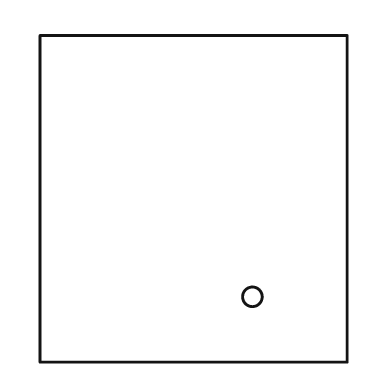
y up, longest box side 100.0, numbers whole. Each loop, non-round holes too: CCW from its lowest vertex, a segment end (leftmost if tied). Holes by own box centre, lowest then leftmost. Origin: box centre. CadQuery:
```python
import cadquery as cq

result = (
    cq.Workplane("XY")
    .moveTo(-47.0, -50.0)
    .lineTo(47.0, -50.0)
    .lineTo(47.0, 50.0)
    .lineTo(-47.0, 50.0)
    .close()
    .moveTo(18.0, -30.0)
    .circle(3.0)
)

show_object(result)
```